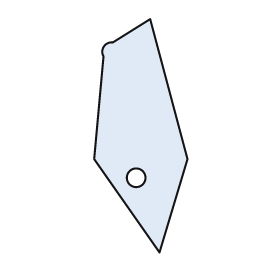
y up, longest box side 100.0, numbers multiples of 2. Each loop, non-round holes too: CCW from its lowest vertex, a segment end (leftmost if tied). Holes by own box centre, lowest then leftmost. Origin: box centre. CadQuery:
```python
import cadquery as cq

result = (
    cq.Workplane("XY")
    .moveTo(8.0, -50.0)
    .lineTo(20.0, -10.0)
    .lineTo(4.0, 50.0)
    .lineTo(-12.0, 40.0)
    .threePointArc((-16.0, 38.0), (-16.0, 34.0))
    .lineTo(-20.0, -10.0)
    .close()
    .moveTo(-2.0, -18.0)
    .circle(4.0)
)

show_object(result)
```